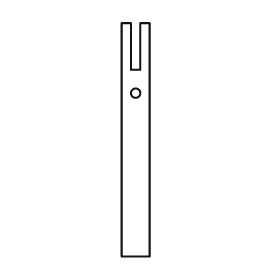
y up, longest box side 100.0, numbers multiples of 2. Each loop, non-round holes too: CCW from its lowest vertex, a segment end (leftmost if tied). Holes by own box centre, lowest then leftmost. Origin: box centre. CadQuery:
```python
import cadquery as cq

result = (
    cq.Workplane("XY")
    .moveTo(-6.0, -50.0)
    .lineTo(6.0, -50.0)
    .lineTo(6.0, 50.0)
    .lineTo(2.0, 50.0)
    .lineTo(2.0, 30.0)
    .lineTo(-2.0, 30.0)
    .lineTo(-2.0, 50.0)
    .lineTo(-6.0, 50.0)
    .close()
    .moveTo(0.0, 20.0)
    .circle(2.0)
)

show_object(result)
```